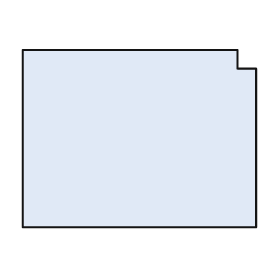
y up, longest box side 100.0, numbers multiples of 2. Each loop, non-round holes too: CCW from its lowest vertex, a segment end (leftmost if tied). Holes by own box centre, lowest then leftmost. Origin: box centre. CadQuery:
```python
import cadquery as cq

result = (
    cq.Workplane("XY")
    .moveTo(-50.0, -38.0)
    .lineTo(50.0, -38.0)
    .lineTo(50.0, 30.0)
    .lineTo(42.0, 30.0)
    .lineTo(42.0, 38.0)
    .lineTo(-50.0, 38.0)
    .close()
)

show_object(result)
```